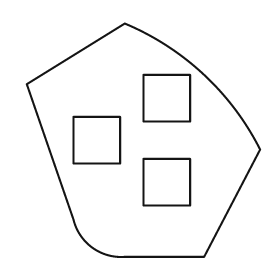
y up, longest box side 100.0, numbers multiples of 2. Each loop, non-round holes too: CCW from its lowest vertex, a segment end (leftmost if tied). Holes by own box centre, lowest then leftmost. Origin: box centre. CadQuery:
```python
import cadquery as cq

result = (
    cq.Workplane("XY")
    .moveTo(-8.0, -50.0)
    .lineTo(26.0, -50.0)
    .lineTo(50.0, -4.0)
    .threePointArc((26.0, 28.0), (-8.0, 50.0))
    .lineTo(-50.0, 24.0)
    .lineTo(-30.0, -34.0)
    .threePointArc((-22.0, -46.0), (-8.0, -50.0))
    .close()
    .moveTo(0.0, -28.0)
    .lineTo(20.0, -28.0)
    .lineTo(20.0, -8.0)
    .lineTo(0.0, -8.0)
    .close()
    .moveTo(-30.0, -10.0)
    .lineTo(-10.0, -10.0)
    .lineTo(-10.0, 10.0)
    .lineTo(-30.0, 10.0)
    .close()
    .moveTo(0.0, 8.0)
    .lineTo(20.0, 8.0)
    .lineTo(20.0, 28.0)
    .lineTo(0.0, 28.0)
    .close()
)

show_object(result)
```